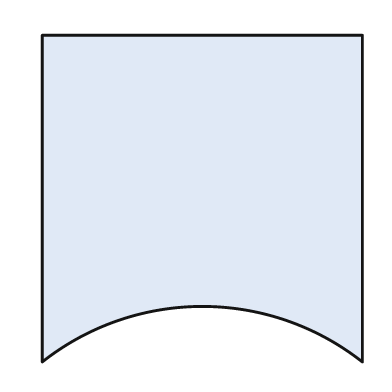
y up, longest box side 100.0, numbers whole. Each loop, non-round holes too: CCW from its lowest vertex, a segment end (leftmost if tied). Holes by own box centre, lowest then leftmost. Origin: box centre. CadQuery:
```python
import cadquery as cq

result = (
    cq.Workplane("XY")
    .moveTo(-49.0, -50.0)
    .threePointArc((0.0, -33.0), (49.0, -50.0))
    .lineTo(49.0, 50.0)
    .lineTo(-49.0, 50.0)
    .close()
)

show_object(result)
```